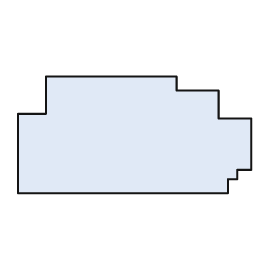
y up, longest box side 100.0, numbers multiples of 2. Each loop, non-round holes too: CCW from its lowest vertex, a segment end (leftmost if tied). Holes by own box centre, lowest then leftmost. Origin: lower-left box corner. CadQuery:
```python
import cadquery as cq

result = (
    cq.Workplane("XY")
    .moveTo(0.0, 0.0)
    .lineTo(90.0, 0.0)
    .lineTo(90.0, 6.0)
    .lineTo(94.0, 6.0)
    .lineTo(94.0, 10.0)
    .lineTo(100.0, 10.0)
    .lineTo(100.0, 32.0)
    .lineTo(86.0, 32.0)
    .lineTo(86.0, 44.0)
    .lineTo(68.0, 44.0)
    .lineTo(68.0, 50.0)
    .lineTo(12.0, 50.0)
    .lineTo(12.0, 34.0)
    .lineTo(0.0, 34.0)
    .close()
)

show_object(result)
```